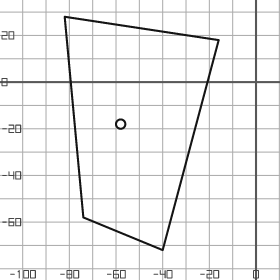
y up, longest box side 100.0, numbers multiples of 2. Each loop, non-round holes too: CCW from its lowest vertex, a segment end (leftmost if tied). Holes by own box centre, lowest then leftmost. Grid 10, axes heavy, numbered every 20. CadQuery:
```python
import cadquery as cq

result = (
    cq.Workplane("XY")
    .moveTo(-40.0, -72.0)
    .lineTo(-16.0, 18.0)
    .lineTo(-82.0, 28.0)
    .lineTo(-74.0, -58.0)
    .close()
    .moveTo(-58.0, -18.0)
    .circle(2.0)
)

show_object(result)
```